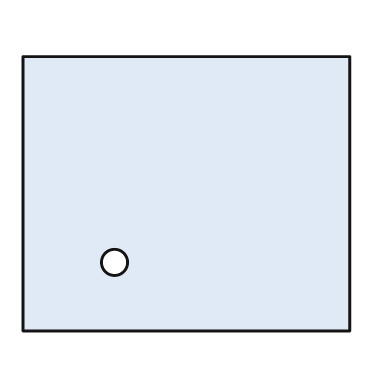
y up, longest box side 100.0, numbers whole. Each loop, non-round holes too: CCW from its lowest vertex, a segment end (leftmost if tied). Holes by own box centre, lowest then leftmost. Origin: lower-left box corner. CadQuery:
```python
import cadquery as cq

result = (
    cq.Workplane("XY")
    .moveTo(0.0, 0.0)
    .lineTo(100.0, 0.0)
    .lineTo(100.0, 84.0)
    .lineTo(0.0, 84.0)
    .close()
    .moveTo(28.0, 21.0)
    .circle(4.0)
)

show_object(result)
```